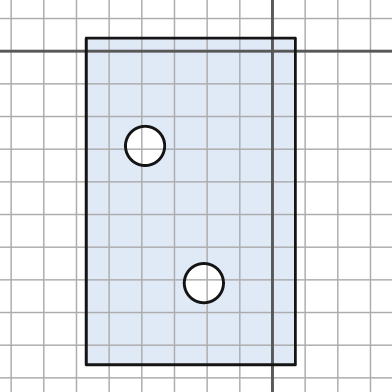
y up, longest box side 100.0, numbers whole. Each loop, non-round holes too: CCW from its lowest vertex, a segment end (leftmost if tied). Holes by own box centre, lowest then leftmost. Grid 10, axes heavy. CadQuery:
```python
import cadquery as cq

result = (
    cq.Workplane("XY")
    .moveTo(-57.0, -96.0)
    .lineTo(7.0, -96.0)
    .lineTo(7.0, 4.0)
    .lineTo(-57.0, 4.0)
    .close()
    .moveTo(-21.0, -71.0)
    .circle(6.0)
    .moveTo(-39.0, -29.0)
    .circle(6.0)
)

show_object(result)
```